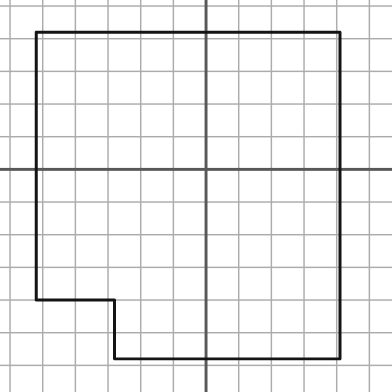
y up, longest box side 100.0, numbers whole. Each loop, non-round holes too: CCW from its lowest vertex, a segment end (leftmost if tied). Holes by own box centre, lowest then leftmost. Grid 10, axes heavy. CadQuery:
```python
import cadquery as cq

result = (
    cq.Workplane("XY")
    .moveTo(-28.0, -58.0)
    .lineTo(41.0, -58.0)
    .lineTo(41.0, 42.0)
    .lineTo(-52.0, 42.0)
    .lineTo(-52.0, -40.0)
    .lineTo(-28.0, -40.0)
    .close()
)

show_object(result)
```